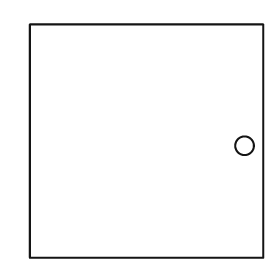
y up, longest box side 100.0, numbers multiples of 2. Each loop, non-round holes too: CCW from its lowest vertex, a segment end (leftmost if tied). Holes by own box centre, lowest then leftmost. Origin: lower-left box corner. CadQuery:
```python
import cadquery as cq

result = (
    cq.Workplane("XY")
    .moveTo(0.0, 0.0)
    .lineTo(100.0, 0.0)
    .lineTo(100.0, 100.0)
    .lineTo(0.0, 100.0)
    .close()
    .moveTo(92.0, 48.0)
    .circle(4.0)
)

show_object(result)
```